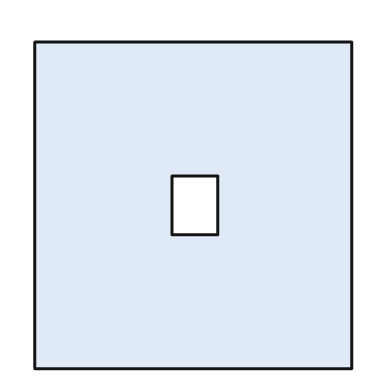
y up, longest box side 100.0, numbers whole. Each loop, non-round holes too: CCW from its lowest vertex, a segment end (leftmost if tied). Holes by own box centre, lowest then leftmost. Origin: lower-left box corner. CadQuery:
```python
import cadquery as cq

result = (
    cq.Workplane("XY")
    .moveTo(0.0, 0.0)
    .lineTo(97.0, 0.0)
    .lineTo(97.0, 100.0)
    .lineTo(0.0, 100.0)
    .close()
    .moveTo(42.0, 41.0)
    .lineTo(56.0, 41.0)
    .lineTo(56.0, 59.0)
    .lineTo(42.0, 59.0)
    .close()
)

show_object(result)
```